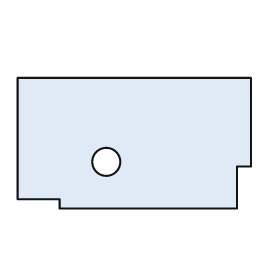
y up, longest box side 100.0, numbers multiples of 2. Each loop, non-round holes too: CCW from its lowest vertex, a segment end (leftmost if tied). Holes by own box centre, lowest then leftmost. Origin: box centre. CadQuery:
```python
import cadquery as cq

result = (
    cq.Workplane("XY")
    .moveTo(-32.0, -28.0)
    .lineTo(44.0, -28.0)
    .lineTo(44.0, -10.0)
    .lineTo(50.0, -10.0)
    .lineTo(50.0, 28.0)
    .lineTo(-50.0, 28.0)
    .lineTo(-50.0, -24.0)
    .lineTo(-32.0, -24.0)
    .close()
    .moveTo(-12.0, -8.0)
    .circle(6.0)
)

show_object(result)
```